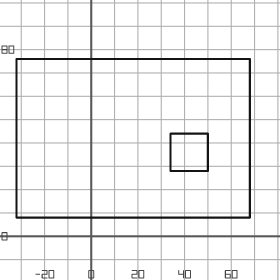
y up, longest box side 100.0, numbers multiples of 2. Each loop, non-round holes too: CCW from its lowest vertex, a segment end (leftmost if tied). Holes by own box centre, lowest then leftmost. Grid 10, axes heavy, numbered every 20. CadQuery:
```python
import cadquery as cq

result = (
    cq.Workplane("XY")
    .moveTo(-32.0, 8.0)
    .lineTo(68.0, 8.0)
    .lineTo(68.0, 76.0)
    .lineTo(-32.0, 76.0)
    .close()
    .moveTo(34.0, 28.0)
    .lineTo(50.0, 28.0)
    .lineTo(50.0, 44.0)
    .lineTo(34.0, 44.0)
    .close()
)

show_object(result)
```